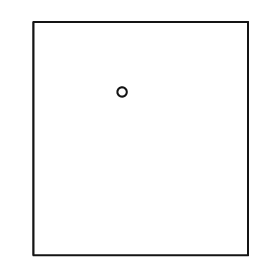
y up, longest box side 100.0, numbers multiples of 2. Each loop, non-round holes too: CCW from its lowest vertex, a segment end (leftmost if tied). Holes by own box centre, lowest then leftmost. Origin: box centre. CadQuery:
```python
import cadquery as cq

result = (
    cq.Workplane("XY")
    .moveTo(-46.0, -50.0)
    .lineTo(46.0, -50.0)
    .lineTo(46.0, 50.0)
    .lineTo(-46.0, 50.0)
    .close()
    .moveTo(-8.0, 20.0)
    .circle(2.0)
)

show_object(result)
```